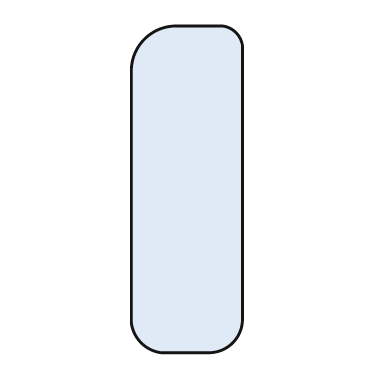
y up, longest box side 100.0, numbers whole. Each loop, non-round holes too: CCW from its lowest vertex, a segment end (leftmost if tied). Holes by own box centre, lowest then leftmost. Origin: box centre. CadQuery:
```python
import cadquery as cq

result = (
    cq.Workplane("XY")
    .moveTo(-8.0, -50.0)
    .lineTo(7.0, -50.0)
    .threePointArc((14.0, -47.0), (17.0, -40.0))
    .lineTo(17.0, 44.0)
    .threePointArc((15.0, 48.0), (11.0, 50.0))
    .lineTo(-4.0, 50.0)
    .threePointArc((-13.0, 46.0), (-17.0, 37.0))
    .lineTo(-17.0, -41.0)
    .threePointArc((-14.0, -47.0), (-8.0, -50.0))
    .close()
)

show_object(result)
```